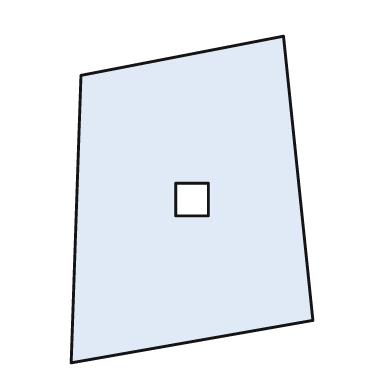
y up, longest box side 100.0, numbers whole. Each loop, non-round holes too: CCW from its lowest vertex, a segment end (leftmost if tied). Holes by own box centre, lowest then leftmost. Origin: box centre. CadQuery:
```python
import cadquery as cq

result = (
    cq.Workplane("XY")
    .moveTo(-37.0, -50.0)
    .lineTo(37.0, -37.0)
    .lineTo(28.0, 50.0)
    .lineTo(-34.0, 38.0)
    .close()
    .moveTo(-5.0, -5.0)
    .lineTo(5.0, -5.0)
    .lineTo(5.0, 5.0)
    .lineTo(-5.0, 5.0)
    .close()
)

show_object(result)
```